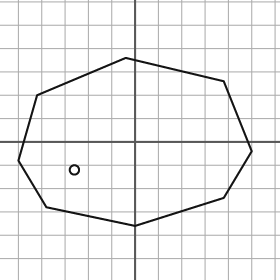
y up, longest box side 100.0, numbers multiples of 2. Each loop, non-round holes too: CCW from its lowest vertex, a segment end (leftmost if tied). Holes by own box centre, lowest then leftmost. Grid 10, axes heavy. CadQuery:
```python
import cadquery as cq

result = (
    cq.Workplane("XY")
    .moveTo(0.0, -36.0)
    .lineTo(38.0, -24.0)
    .lineTo(50.0, -4.0)
    .lineTo(38.0, 26.0)
    .lineTo(-4.0, 36.0)
    .lineTo(-42.0, 20.0)
    .lineTo(-50.0, -8.0)
    .lineTo(-38.0, -28.0)
    .close()
    .moveTo(-26.0, -12.0)
    .circle(2.0)
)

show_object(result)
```